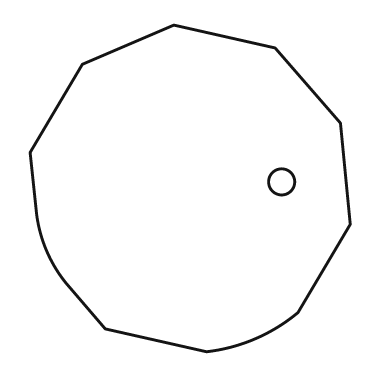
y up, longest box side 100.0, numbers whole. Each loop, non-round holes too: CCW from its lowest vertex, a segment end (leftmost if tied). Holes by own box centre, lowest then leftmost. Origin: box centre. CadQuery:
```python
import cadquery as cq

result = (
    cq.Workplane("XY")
    .moveTo(5.0, -50.0)
    .threePointArc((20.0, -46.0), (33.0, -38.0))
    .lineTo(49.0, -11.0)
    .lineTo(46.0, 20.0)
    .lineTo(26.0, 43.0)
    .lineTo(-5.0, 50.0)
    .lineTo(-33.0, 38.0)
    .lineTo(-49.0, 11.0)
    .lineTo(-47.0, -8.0)
    .threePointArc((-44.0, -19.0), (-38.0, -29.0))
    .lineTo(-26.0, -43.0)
    .close()
    .moveTo(28.0, 2.0)
    .circle(4.0)
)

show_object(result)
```